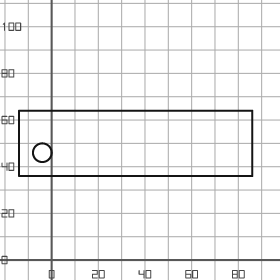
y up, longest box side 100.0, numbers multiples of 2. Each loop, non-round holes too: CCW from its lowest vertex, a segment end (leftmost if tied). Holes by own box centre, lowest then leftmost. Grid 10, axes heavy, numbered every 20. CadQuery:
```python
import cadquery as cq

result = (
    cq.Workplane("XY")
    .moveTo(-14.0, 36.0)
    .lineTo(86.0, 36.0)
    .lineTo(86.0, 64.0)
    .lineTo(-14.0, 64.0)
    .close()
    .moveTo(-4.0, 46.0)
    .circle(4.0)
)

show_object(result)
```